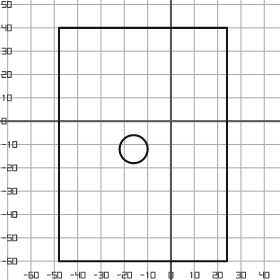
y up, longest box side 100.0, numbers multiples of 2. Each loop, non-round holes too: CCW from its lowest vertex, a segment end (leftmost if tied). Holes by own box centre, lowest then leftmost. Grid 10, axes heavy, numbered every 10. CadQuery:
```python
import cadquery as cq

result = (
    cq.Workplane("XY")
    .moveTo(-48.0, -60.0)
    .lineTo(24.0, -60.0)
    .lineTo(24.0, 40.0)
    .lineTo(-48.0, 40.0)
    .close()
    .moveTo(-16.0, -12.0)
    .circle(6.0)
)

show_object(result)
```